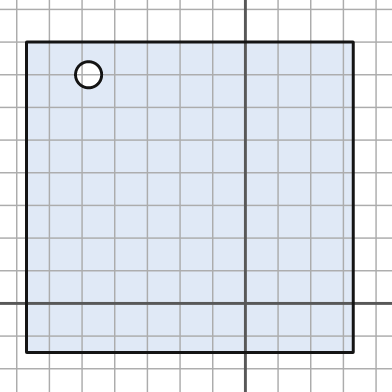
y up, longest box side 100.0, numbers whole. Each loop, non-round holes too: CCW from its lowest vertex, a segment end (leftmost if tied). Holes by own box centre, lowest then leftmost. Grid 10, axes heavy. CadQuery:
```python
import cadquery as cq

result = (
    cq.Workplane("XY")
    .moveTo(-67.0, -15.0)
    .lineTo(33.0, -15.0)
    .lineTo(33.0, 80.0)
    .lineTo(-67.0, 80.0)
    .close()
    .moveTo(-48.0, 70.0)
    .circle(4.0)
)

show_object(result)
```